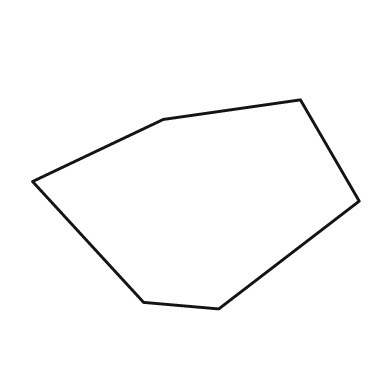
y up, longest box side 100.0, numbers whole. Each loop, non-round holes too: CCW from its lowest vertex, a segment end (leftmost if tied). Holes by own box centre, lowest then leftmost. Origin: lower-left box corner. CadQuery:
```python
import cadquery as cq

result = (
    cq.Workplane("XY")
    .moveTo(57.0, 0.0)
    .lineTo(100.0, 33.0)
    .lineTo(82.0, 64.0)
    .lineTo(40.0, 58.0)
    .lineTo(0.0, 39.0)
    .lineTo(34.0, 2.0)
    .close()
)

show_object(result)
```